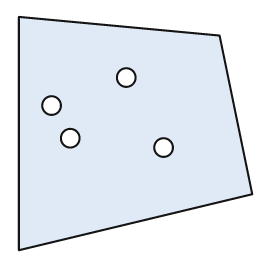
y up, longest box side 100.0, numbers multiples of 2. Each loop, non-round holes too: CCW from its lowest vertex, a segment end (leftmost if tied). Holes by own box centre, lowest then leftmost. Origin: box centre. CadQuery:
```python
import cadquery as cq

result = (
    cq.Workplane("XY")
    .moveTo(-50.0, -50.0)
    .lineTo(50.0, -26.0)
    .lineTo(36.0, 42.0)
    .lineTo(-50.0, 50.0)
    .close()
    .moveTo(12.0, -6.0)
    .circle(4.0)
    .moveTo(-28.0, -2.0)
    .circle(4.0)
    .moveTo(-36.0, 12.0)
    .circle(4.0)
    .moveTo(-4.0, 24.0)
    .circle(4.0)
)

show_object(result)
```